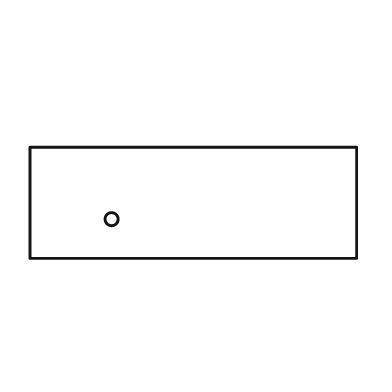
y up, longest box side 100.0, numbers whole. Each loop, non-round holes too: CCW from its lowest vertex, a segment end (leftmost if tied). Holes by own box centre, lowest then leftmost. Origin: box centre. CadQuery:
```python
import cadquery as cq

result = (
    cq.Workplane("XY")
    .moveTo(-50.0, -17.0)
    .lineTo(50.0, -17.0)
    .lineTo(50.0, 17.0)
    .lineTo(-50.0, 17.0)
    .close()
    .moveTo(-25.0, -5.0)
    .circle(2.0)
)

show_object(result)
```